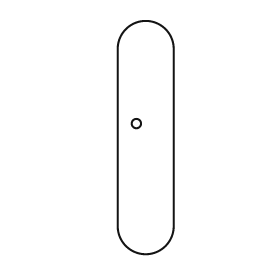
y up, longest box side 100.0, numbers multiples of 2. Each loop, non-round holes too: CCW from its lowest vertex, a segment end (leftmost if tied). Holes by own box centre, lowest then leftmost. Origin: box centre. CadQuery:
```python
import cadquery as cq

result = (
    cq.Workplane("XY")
    .moveTo(-12.0, -38.0)
    .threePointArc((0.0, -50.0), (12.0, -38.0))
    .lineTo(12.0, 38.0)
    .threePointArc((0.0, 50.0), (-12.0, 38.0))
    .close()
    .moveTo(-4.0, 6.0)
    .circle(2.0)
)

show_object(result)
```